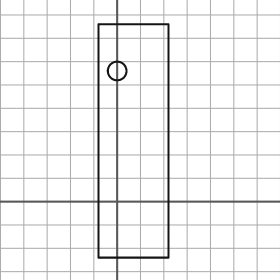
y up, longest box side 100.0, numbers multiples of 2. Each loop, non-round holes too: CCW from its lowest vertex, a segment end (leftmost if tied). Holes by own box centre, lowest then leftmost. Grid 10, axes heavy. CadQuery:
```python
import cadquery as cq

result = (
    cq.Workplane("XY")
    .moveTo(-8.0, -24.0)
    .lineTo(22.0, -24.0)
    .lineTo(22.0, 76.0)
    .lineTo(-8.0, 76.0)
    .close()
    .moveTo(0.0, 56.0)
    .circle(4.0)
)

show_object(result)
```